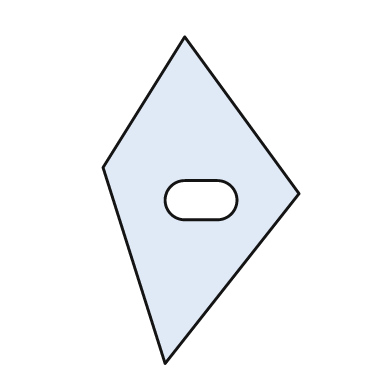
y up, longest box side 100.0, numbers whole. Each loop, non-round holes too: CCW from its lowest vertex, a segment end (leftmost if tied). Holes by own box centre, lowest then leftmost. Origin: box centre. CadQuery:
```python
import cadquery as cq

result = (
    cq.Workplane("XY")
    .moveTo(-11.0, -50.0)
    .lineTo(30.0, 2.0)
    .lineTo(-5.0, 50.0)
    .lineTo(-30.0, 10.0)
    .close()
    .moveTo(-5.0, -6.0)
    .lineTo(5.0, -6.0)
    .threePointArc((11.0, 0.0), (5.0, 6.0))
    .lineTo(-5.0, 6.0)
    .threePointArc((-11.0, 0.0), (-5.0, -6.0))
    .close()
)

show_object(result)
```